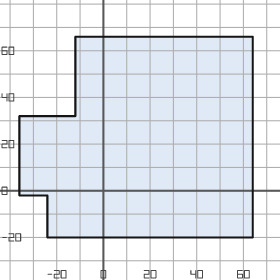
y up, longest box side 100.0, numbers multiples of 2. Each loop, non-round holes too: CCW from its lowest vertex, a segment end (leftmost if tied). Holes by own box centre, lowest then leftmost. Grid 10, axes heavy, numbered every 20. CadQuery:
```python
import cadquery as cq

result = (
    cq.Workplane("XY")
    .moveTo(-24.0, -20.0)
    .lineTo(64.0, -20.0)
    .lineTo(64.0, 66.0)
    .lineTo(-12.0, 66.0)
    .lineTo(-12.0, 32.0)
    .lineTo(-36.0, 32.0)
    .lineTo(-36.0, -2.0)
    .lineTo(-24.0, -2.0)
    .close()
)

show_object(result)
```